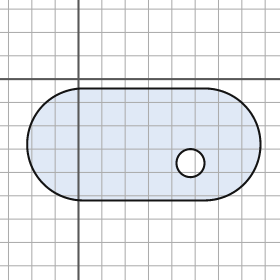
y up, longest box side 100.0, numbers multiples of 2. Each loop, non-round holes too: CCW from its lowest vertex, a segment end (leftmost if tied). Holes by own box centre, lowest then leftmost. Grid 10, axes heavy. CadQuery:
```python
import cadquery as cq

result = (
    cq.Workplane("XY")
    .moveTo(2.0, -52.0)
    .lineTo(54.0, -52.0)
    .threePointArc((78.0, -28.0), (54.0, -4.0))
    .lineTo(2.0, -4.0)
    .threePointArc((-22.0, -28.0), (2.0, -52.0))
    .close()
    .moveTo(48.0, -36.0)
    .circle(6.0)
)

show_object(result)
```